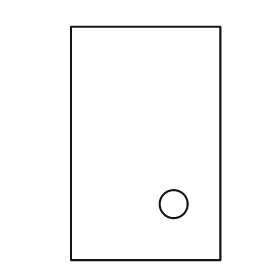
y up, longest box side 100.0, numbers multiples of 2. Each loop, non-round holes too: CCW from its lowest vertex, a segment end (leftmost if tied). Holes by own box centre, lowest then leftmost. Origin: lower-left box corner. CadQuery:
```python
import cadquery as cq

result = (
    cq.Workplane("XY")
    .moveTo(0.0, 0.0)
    .lineTo(64.0, 0.0)
    .lineTo(64.0, 100.0)
    .lineTo(0.0, 100.0)
    .close()
    .moveTo(44.0, 24.0)
    .circle(6.0)
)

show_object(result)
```